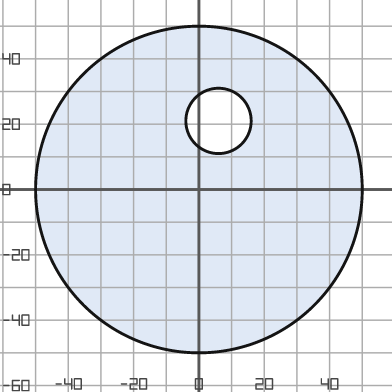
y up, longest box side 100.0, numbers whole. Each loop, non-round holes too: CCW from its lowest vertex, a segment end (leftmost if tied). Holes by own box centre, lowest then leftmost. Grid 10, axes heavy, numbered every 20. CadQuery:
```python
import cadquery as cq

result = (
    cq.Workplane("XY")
    .moveTo(0.0, 0.0)
    .circle(50.0)
    .moveTo(6.0, 21.0)
    .circle(10.0)
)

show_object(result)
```